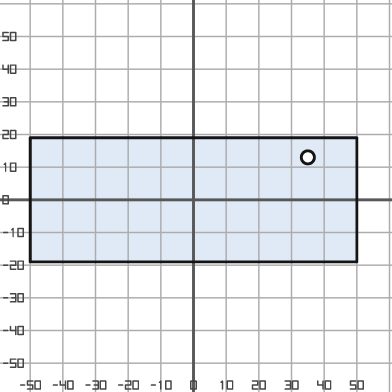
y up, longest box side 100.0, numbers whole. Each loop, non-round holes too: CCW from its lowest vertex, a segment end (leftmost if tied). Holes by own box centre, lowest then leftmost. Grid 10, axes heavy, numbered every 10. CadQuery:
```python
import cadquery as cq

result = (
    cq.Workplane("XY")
    .moveTo(-50.0, -19.0)
    .lineTo(50.0, -19.0)
    .lineTo(50.0, 19.0)
    .lineTo(-50.0, 19.0)
    .close()
    .moveTo(35.0, 13.0)
    .circle(2.0)
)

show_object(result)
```